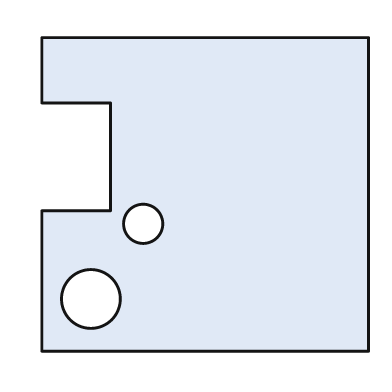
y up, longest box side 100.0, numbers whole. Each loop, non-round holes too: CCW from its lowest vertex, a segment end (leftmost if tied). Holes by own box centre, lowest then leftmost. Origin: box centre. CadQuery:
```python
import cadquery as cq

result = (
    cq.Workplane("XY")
    .moveTo(-50.0, -48.0)
    .lineTo(50.0, -48.0)
    .lineTo(50.0, 48.0)
    .lineTo(-50.0, 48.0)
    .lineTo(-50.0, 28.0)
    .lineTo(-29.0, 28.0)
    .lineTo(-29.0, -5.0)
    .lineTo(-50.0, -5.0)
    .close()
    .moveTo(-35.0, -32.0)
    .circle(9.0)
    .moveTo(-19.0, -9.0)
    .circle(6.0)
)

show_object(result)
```